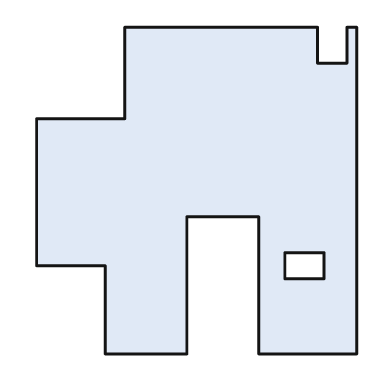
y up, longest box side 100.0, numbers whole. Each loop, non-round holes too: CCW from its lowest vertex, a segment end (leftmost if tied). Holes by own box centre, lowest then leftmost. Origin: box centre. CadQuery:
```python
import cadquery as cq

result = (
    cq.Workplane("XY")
    .moveTo(-28.0, -50.0)
    .lineTo(-3.0, -50.0)
    .lineTo(-3.0, -8.0)
    .lineTo(19.0, -8.0)
    .lineTo(19.0, -50.0)
    .lineTo(49.0, -50.0)
    .lineTo(49.0, 50.0)
    .lineTo(46.0, 50.0)
    .lineTo(46.0, 39.0)
    .lineTo(37.0, 39.0)
    .lineTo(37.0, 50.0)
    .lineTo(-22.0, 50.0)
    .lineTo(-22.0, 22.0)
    .lineTo(-49.0, 22.0)
    .lineTo(-49.0, -23.0)
    .lineTo(-28.0, -23.0)
    .close()
    .moveTo(27.0, -27.0)
    .lineTo(39.0, -27.0)
    .lineTo(39.0, -19.0)
    .lineTo(27.0, -19.0)
    .close()
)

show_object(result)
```